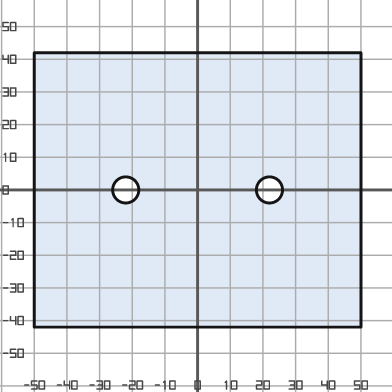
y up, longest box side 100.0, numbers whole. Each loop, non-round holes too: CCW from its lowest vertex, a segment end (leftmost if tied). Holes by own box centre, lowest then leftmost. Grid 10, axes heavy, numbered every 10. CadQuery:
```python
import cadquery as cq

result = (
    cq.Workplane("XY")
    .moveTo(-50.0, -42.0)
    .lineTo(50.0, -42.0)
    .lineTo(50.0, 42.0)
    .lineTo(-50.0, 42.0)
    .close()
    .moveTo(-22.0, 0.0)
    .circle(4.0)
    .moveTo(22.0, 0.0)
    .circle(4.0)
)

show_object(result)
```